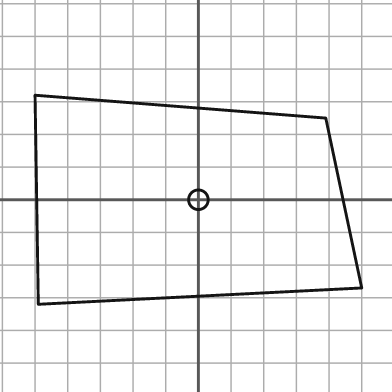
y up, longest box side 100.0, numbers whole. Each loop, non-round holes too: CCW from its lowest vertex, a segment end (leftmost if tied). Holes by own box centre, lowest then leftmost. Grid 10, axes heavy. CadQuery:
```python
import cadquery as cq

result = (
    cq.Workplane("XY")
    .moveTo(-49.0, -32.0)
    .lineTo(50.0, -27.0)
    .lineTo(39.0, 25.0)
    .lineTo(-50.0, 32.0)
    .close()
    .moveTo(0.0, 0.0)
    .circle(3.0)
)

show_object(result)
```